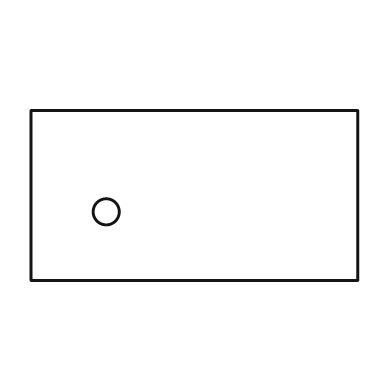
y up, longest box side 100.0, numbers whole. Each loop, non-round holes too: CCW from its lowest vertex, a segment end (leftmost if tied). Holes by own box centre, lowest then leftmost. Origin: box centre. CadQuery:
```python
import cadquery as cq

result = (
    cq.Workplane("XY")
    .moveTo(-50.0, -26.0)
    .lineTo(50.0, -26.0)
    .lineTo(50.0, 26.0)
    .lineTo(-50.0, 26.0)
    .close()
    .moveTo(-27.0, -5.0)
    .circle(4.0)
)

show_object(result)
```